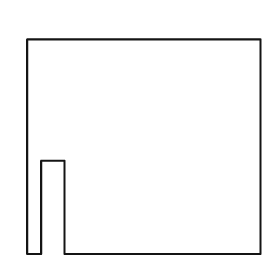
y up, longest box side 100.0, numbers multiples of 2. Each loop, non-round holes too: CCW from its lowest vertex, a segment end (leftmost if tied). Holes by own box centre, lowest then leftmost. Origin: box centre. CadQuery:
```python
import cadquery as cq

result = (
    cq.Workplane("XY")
    .moveTo(-50.0, -46.0)
    .lineTo(-44.0, -46.0)
    .lineTo(-44.0, -6.0)
    .lineTo(-34.0, -6.0)
    .lineTo(-34.0, -46.0)
    .lineTo(50.0, -46.0)
    .lineTo(50.0, 46.0)
    .lineTo(-50.0, 46.0)
    .close()
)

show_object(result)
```